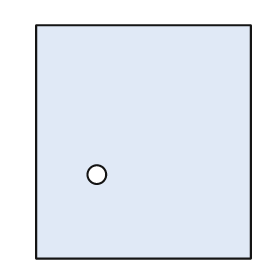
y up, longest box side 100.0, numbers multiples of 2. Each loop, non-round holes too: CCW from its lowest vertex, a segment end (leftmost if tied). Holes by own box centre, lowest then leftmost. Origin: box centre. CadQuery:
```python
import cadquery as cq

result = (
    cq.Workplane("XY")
    .moveTo(-46.0, -50.0)
    .lineTo(46.0, -50.0)
    .lineTo(46.0, 50.0)
    .lineTo(-46.0, 50.0)
    .close()
    .moveTo(-20.0, -14.0)
    .circle(4.0)
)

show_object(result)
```